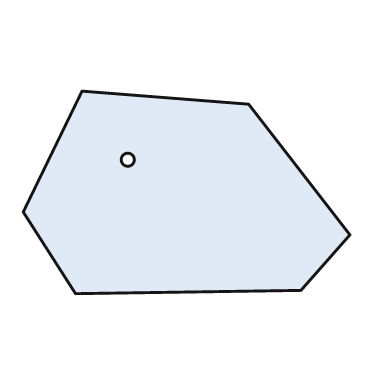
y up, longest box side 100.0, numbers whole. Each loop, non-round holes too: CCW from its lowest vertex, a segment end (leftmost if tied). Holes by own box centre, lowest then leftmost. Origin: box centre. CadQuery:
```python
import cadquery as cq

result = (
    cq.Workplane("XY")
    .moveTo(-34.0, -31.0)
    .lineTo(35.0, -30.0)
    .lineTo(50.0, -13.0)
    .lineTo(19.0, 27.0)
    .lineTo(-32.0, 31.0)
    .lineTo(-50.0, -6.0)
    .close()
    .moveTo(-18.0, 10.0)
    .circle(2.0)
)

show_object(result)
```